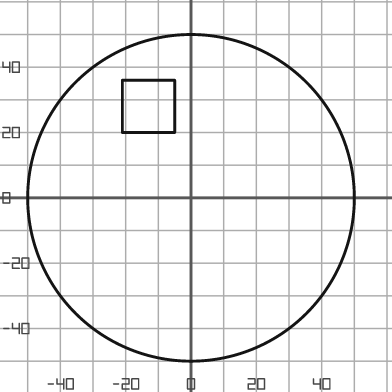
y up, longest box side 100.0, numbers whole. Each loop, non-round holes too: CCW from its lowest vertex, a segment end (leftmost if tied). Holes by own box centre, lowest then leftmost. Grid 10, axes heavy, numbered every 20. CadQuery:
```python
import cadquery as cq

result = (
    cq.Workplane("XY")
    .moveTo(0.0, 0.0)
    .circle(50.0)
    .moveTo(-21.0, 20.0)
    .lineTo(-5.0, 20.0)
    .lineTo(-5.0, 36.0)
    .lineTo(-21.0, 36.0)
    .close()
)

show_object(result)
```